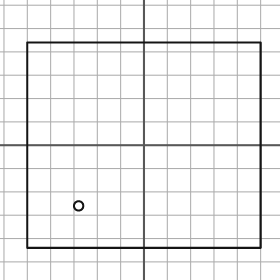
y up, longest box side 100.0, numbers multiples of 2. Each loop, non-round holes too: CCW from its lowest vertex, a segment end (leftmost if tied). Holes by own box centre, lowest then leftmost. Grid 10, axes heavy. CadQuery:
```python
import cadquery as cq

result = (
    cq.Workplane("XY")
    .moveTo(-50.0, -44.0)
    .lineTo(50.0, -44.0)
    .lineTo(50.0, 44.0)
    .lineTo(-50.0, 44.0)
    .close()
    .moveTo(-28.0, -26.0)
    .circle(2.0)
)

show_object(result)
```